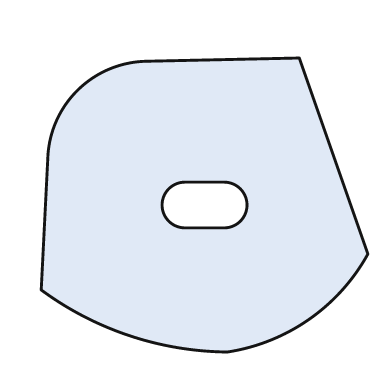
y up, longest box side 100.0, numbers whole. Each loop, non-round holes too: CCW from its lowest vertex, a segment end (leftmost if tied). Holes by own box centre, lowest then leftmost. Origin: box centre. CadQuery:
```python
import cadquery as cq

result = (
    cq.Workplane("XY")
    .moveTo(7.0, -45.0)
    .threePointArc((32.0, -35.0), (50.0, -15.0))
    .lineTo(29.0, 45.0)
    .lineTo(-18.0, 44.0)
    .threePointArc((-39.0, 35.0), (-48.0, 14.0))
    .lineTo(-50.0, -26.0)
    .threePointArc((-23.0, -40.0), (7.0, -45.0))
    .close()
    .moveTo(-6.0, -7.0)
    .lineTo(6.0, -7.0)
    .threePointArc((13.0, 0.0), (6.0, 7.0))
    .lineTo(-6.0, 7.0)
    .threePointArc((-13.0, 0.0), (-6.0, -7.0))
    .close()
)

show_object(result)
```